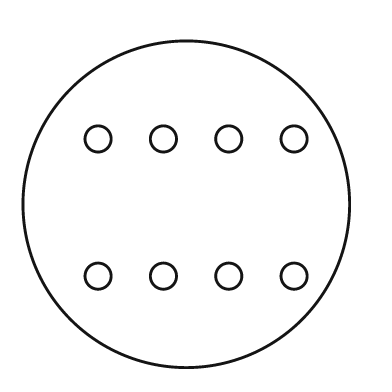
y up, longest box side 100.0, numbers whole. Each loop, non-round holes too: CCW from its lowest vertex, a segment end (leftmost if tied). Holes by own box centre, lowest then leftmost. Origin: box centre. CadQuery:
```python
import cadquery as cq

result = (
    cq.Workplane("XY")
    .moveTo(0.0, 0.0)
    .circle(50.0)
    .moveTo(-27.0, -22.0)
    .circle(4.0)
    .moveTo(-7.0, -22.0)
    .circle(4.0)
    .moveTo(13.0, -22.0)
    .circle(4.0)
    .moveTo(33.0, -22.0)
    .circle(4.0)
    .moveTo(-27.0, 20.0)
    .circle(4.0)
    .moveTo(-7.0, 20.0)
    .circle(4.0)
    .moveTo(13.0, 20.0)
    .circle(4.0)
    .moveTo(33.0, 20.0)
    .circle(4.0)
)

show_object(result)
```